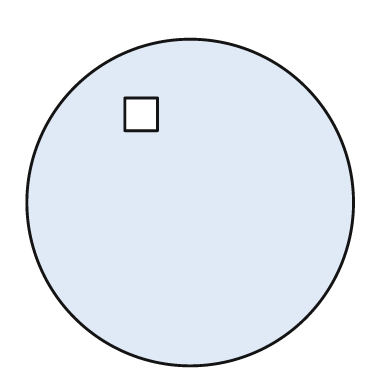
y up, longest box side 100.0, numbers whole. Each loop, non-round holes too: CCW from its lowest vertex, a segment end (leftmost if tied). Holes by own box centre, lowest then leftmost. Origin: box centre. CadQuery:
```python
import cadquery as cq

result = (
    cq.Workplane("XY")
    .moveTo(0.0, 0.0)
    .circle(50.0)
    .moveTo(-20.0, 22.0)
    .lineTo(-10.0, 22.0)
    .lineTo(-10.0, 32.0)
    .lineTo(-20.0, 32.0)
    .close()
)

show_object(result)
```